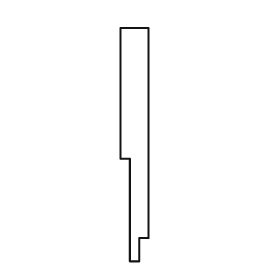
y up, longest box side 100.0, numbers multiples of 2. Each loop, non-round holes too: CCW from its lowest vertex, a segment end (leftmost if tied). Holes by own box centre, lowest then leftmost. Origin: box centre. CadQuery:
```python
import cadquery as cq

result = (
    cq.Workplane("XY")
    .moveTo(-2.0, -50.0)
    .lineTo(2.0, -50.0)
    .lineTo(2.0, -40.0)
    .lineTo(6.0, -40.0)
    .lineTo(6.0, 50.0)
    .lineTo(-6.0, 50.0)
    .lineTo(-6.0, -6.0)
    .lineTo(-2.0, -6.0)
    .close()
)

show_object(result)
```